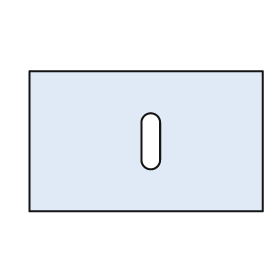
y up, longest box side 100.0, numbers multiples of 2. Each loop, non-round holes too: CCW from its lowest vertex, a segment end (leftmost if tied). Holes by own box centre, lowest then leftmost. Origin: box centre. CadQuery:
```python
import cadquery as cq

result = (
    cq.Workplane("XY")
    .moveTo(-50.0, -30.0)
    .lineTo(50.0, -30.0)
    .lineTo(50.0, 30.0)
    .lineTo(-50.0, 30.0)
    .close()
    .moveTo(-2.0, -8.0)
    .threePointArc((2.0, -12.0), (6.0, -8.0))
    .lineTo(6.0, 8.0)
    .threePointArc((2.0, 12.0), (-2.0, 8.0))
    .close()
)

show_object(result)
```